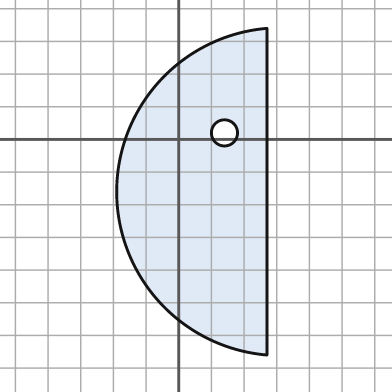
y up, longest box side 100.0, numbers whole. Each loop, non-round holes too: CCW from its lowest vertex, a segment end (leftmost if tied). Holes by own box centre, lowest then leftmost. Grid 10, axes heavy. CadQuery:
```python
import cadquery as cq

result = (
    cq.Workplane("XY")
    .moveTo(27.0, -66.0)
    .lineTo(27.0, 34.0)
    .threePointArc((-19.0, -16.0), (27.0, -66.0))
    .close()
    .moveTo(14.0, 2.0)
    .circle(4.0)
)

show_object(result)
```